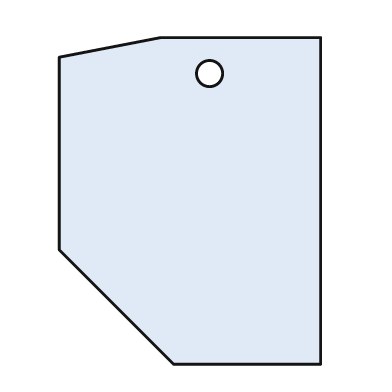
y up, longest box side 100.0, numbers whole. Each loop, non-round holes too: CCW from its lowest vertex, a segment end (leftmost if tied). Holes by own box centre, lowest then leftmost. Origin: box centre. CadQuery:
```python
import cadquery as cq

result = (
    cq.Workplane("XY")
    .moveTo(-5.0, -50.0)
    .lineTo(40.0, -50.0)
    .lineTo(40.0, 50.0)
    .lineTo(-9.0, 50.0)
    .lineTo(-40.0, 44.0)
    .lineTo(-40.0, -15.0)
    .close()
    .moveTo(6.0, 39.0)
    .circle(4.0)
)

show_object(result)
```